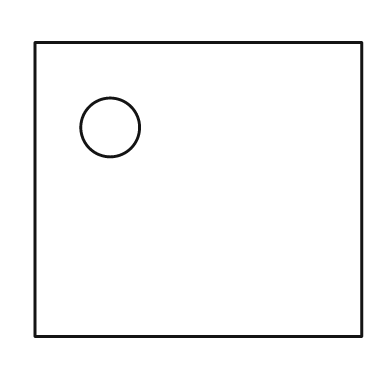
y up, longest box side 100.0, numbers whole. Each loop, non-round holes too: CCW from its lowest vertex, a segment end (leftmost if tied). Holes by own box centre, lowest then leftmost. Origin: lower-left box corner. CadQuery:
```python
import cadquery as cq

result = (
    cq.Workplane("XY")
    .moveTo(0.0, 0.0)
    .lineTo(100.0, 0.0)
    .lineTo(100.0, 90.0)
    .lineTo(0.0, 90.0)
    .close()
    .moveTo(23.0, 64.0)
    .circle(9.0)
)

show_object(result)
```